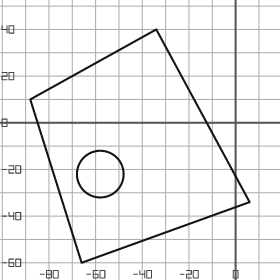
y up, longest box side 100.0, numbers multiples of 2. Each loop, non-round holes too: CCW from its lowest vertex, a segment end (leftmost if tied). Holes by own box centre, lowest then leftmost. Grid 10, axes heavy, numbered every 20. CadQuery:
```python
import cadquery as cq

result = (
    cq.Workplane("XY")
    .moveTo(-66.0, -60.0)
    .lineTo(6.0, -34.0)
    .lineTo(-34.0, 40.0)
    .lineTo(-88.0, 10.0)
    .close()
    .moveTo(-58.0, -22.0)
    .circle(10.0)
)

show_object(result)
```